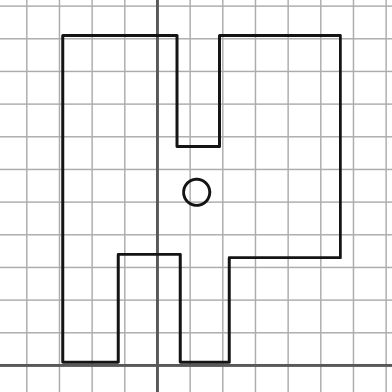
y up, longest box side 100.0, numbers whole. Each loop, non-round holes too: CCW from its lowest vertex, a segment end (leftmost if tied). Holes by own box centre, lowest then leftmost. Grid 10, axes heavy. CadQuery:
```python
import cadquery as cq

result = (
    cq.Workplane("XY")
    .moveTo(-29.0, 1.0)
    .lineTo(-12.0, 1.0)
    .lineTo(-12.0, 34.0)
    .lineTo(7.0, 34.0)
    .lineTo(7.0, 1.0)
    .lineTo(22.0, 1.0)
    .lineTo(22.0, 33.0)
    .lineTo(56.0, 33.0)
    .lineTo(56.0, 101.0)
    .lineTo(19.0, 101.0)
    .lineTo(19.0, 67.0)
    .lineTo(6.0, 67.0)
    .lineTo(6.0, 101.0)
    .lineTo(-29.0, 101.0)
    .close()
    .moveTo(12.0, 53.0)
    .circle(4.0)
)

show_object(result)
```